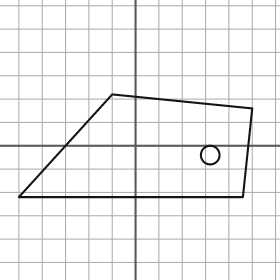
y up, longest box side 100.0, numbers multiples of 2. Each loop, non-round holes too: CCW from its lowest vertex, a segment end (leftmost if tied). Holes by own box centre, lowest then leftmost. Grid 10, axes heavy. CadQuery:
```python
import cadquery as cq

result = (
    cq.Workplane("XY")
    .moveTo(-50.0, -22.0)
    .lineTo(46.0, -22.0)
    .lineTo(50.0, 16.0)
    .lineTo(-10.0, 22.0)
    .close()
    .moveTo(32.0, -4.0)
    .circle(4.0)
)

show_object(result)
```